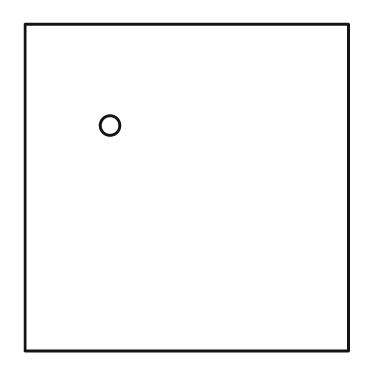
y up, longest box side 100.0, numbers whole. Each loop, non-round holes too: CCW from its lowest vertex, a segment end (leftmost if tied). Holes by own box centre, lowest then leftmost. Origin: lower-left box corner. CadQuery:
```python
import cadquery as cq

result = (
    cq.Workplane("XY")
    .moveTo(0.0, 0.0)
    .lineTo(99.0, 0.0)
    .lineTo(99.0, 100.0)
    .lineTo(0.0, 100.0)
    .close()
    .moveTo(26.0, 69.0)
    .circle(3.0)
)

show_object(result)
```